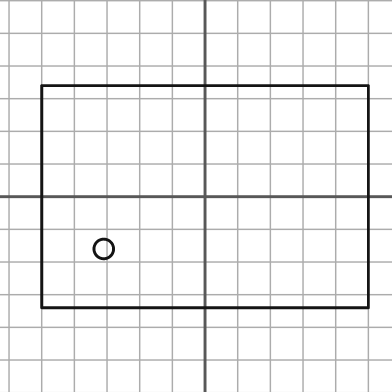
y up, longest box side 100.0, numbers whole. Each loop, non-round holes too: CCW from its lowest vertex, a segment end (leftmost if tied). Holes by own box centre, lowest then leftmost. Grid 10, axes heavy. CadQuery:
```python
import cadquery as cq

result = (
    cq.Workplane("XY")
    .moveTo(-50.0, -34.0)
    .lineTo(50.0, -34.0)
    .lineTo(50.0, 34.0)
    .lineTo(-50.0, 34.0)
    .close()
    .moveTo(-31.0, -16.0)
    .circle(3.0)
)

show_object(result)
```